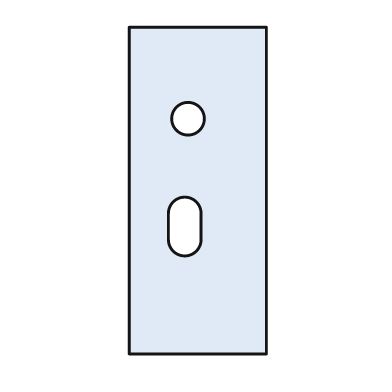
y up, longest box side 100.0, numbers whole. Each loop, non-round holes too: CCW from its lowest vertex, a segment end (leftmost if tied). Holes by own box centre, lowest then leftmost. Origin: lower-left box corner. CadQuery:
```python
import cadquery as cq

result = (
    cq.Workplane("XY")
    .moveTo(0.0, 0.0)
    .lineTo(42.0, 0.0)
    .lineTo(42.0, 100.0)
    .lineTo(0.0, 100.0)
    .close()
    .moveTo(12.0, 35.0)
    .threePointArc((17.0, 30.0), (22.0, 35.0))
    .lineTo(22.0, 43.0)
    .threePointArc((17.0, 48.0), (12.0, 43.0))
    .close()
    .moveTo(18.0, 72.0)
    .circle(5.0)
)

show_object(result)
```